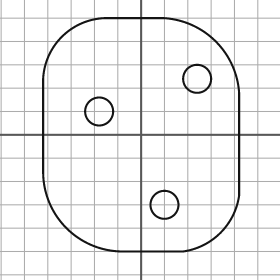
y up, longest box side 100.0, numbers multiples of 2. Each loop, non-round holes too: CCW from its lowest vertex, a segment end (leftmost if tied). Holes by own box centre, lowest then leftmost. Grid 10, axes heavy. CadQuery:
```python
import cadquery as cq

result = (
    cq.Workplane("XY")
    .moveTo(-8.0, -50.0)
    .lineTo(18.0, -50.0)
    .threePointArc((34.0, -42.0), (42.0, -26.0))
    .lineTo(42.0, 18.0)
    .threePointArc((32.0, 40.0), (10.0, 50.0))
    .lineTo(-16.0, 50.0)
    .threePointArc((-34.0, 42.0), (-42.0, 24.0))
    .lineTo(-42.0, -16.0)
    .threePointArc((-32.0, -40.0), (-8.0, -50.0))
    .close()
    .moveTo(10.0, -30.0)
    .circle(6.0)
    .moveTo(-18.0, 10.0)
    .circle(6.0)
    .moveTo(24.0, 24.0)
    .circle(6.0)
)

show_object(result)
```